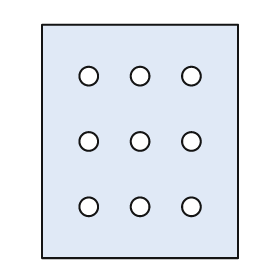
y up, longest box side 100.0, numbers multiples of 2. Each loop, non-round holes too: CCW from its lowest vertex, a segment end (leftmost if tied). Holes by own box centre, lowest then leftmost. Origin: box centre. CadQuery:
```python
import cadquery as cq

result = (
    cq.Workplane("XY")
    .moveTo(-42.0, -50.0)
    .lineTo(42.0, -50.0)
    .lineTo(42.0, 50.0)
    .lineTo(-42.0, 50.0)
    .close()
    .moveTo(-22.0, -28.0)
    .circle(4.0)
    .moveTo(0.0, -28.0)
    .circle(4.0)
    .moveTo(22.0, -28.0)
    .circle(4.0)
    .moveTo(-22.0, 0.0)
    .circle(4.0)
    .moveTo(0.0, 0.0)
    .circle(4.0)
    .moveTo(22.0, 0.0)
    .circle(4.0)
    .moveTo(-22.0, 28.0)
    .circle(4.0)
    .moveTo(0.0, 28.0)
    .circle(4.0)
    .moveTo(22.0, 28.0)
    .circle(4.0)
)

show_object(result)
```